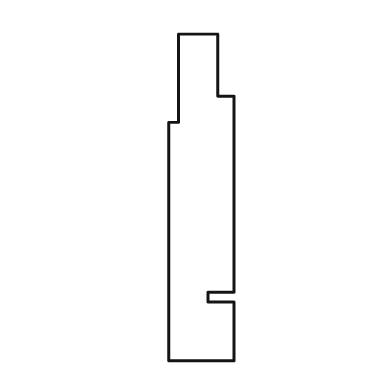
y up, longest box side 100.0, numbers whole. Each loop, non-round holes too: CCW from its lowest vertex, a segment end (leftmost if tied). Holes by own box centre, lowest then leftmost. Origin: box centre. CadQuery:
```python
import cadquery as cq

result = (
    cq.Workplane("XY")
    .moveTo(-10.0, -50.0)
    .lineTo(10.0, -50.0)
    .lineTo(10.0, -32.0)
    .lineTo(2.0, -32.0)
    .lineTo(2.0, -29.0)
    .lineTo(10.0, -29.0)
    .lineTo(10.0, 31.0)
    .lineTo(5.0, 31.0)
    .lineTo(5.0, 50.0)
    .lineTo(-7.0, 50.0)
    .lineTo(-7.0, 23.0)
    .lineTo(-10.0, 23.0)
    .close()
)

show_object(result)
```